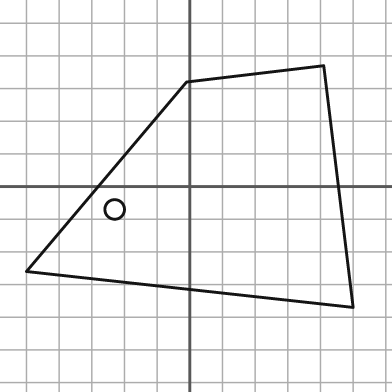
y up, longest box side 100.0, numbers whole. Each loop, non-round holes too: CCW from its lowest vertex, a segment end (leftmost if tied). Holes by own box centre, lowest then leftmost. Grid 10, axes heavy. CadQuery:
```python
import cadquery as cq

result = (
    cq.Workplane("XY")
    .moveTo(50.0, -37.0)
    .lineTo(41.0, 37.0)
    .lineTo(-1.0, 32.0)
    .lineTo(-50.0, -26.0)
    .close()
    .moveTo(-23.0, -7.0)
    .circle(3.0)
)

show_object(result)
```